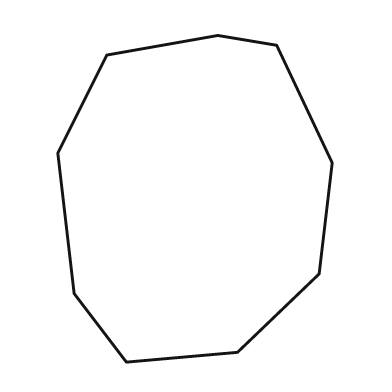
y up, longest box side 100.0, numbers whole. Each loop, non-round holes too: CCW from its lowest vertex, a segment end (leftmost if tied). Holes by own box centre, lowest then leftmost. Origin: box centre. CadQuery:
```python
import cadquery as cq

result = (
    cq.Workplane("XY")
    .moveTo(-21.0, -50.0)
    .lineTo(13.0, -47.0)
    .lineTo(38.0, -23.0)
    .lineTo(42.0, 11.0)
    .lineTo(25.0, 47.0)
    .lineTo(7.0, 50.0)
    .lineTo(-27.0, 44.0)
    .lineTo(-42.0, 14.0)
    .lineTo(-37.0, -29.0)
    .close()
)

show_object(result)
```